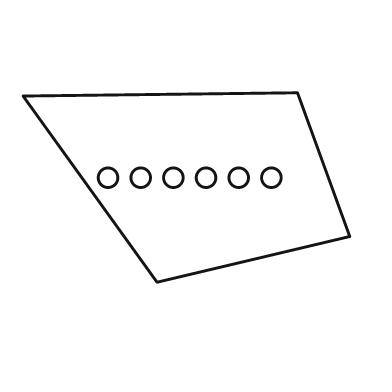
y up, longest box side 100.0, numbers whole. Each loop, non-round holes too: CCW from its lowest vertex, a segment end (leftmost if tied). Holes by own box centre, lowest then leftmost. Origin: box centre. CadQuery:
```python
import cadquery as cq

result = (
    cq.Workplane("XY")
    .moveTo(-9.0, -29.0)
    .lineTo(50.0, -15.0)
    .lineTo(34.0, 29.0)
    .lineTo(-50.0, 28.0)
    .close()
    .moveTo(-24.0, 3.0)
    .circle(3.0)
    .moveTo(-14.0, 3.0)
    .circle(3.0)
    .moveTo(-4.0, 3.0)
    .circle(3.0)
    .moveTo(6.0, 3.0)
    .circle(3.0)
    .moveTo(16.0, 3.0)
    .circle(3.0)
    .moveTo(26.0, 3.0)
    .circle(3.0)
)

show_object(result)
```